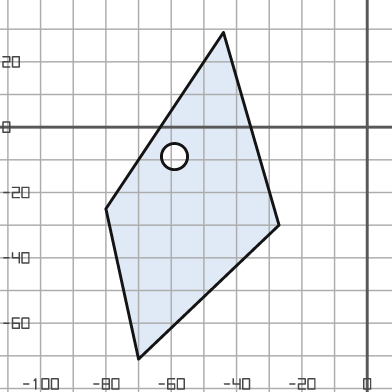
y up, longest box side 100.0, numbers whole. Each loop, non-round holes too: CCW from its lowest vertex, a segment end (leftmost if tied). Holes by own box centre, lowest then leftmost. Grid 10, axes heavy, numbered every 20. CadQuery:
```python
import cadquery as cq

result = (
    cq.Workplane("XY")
    .moveTo(-70.0, -71.0)
    .lineTo(-27.0, -30.0)
    .lineTo(-44.0, 29.0)
    .lineTo(-80.0, -25.0)
    .close()
    .moveTo(-59.0, -9.0)
    .circle(4.0)
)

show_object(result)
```